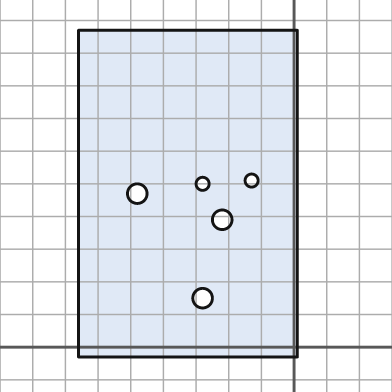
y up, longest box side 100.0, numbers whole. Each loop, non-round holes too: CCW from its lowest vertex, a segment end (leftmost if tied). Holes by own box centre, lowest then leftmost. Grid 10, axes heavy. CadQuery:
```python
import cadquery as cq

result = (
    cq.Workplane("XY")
    .moveTo(-66.0, -3.0)
    .lineTo(1.0, -3.0)
    .lineTo(1.0, 97.0)
    .lineTo(-66.0, 97.0)
    .close()
    .moveTo(-28.0, 15.0)
    .circle(3.0)
    .moveTo(-22.0, 39.0)
    .circle(3.0)
    .moveTo(-48.0, 47.0)
    .circle(3.0)
    .moveTo(-28.0, 50.0)
    .circle(2.0)
    .moveTo(-13.0, 51.0)
    .circle(2.0)
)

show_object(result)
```